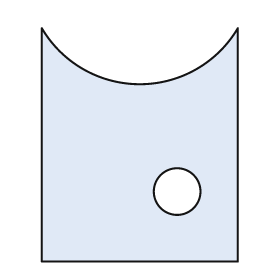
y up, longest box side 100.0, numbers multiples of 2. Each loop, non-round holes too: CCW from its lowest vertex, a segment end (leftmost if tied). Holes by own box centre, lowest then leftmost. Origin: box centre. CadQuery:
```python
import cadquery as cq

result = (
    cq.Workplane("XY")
    .moveTo(-42.0, -50.0)
    .lineTo(42.0, -50.0)
    .lineTo(42.0, 50.0)
    .threePointArc((0.0, 26.0), (-42.0, 50.0))
    .close()
    .moveTo(16.0, -20.0)
    .circle(10.0)
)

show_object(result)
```